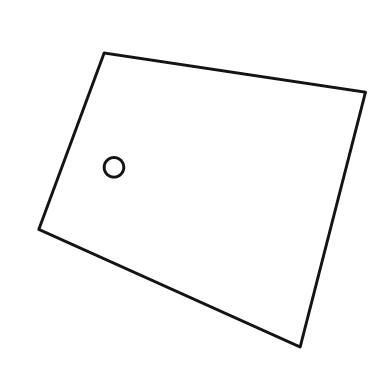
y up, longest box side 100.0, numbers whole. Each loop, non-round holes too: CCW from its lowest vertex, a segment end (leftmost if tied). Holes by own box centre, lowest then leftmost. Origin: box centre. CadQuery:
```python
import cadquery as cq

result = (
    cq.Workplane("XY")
    .moveTo(30.0, -45.0)
    .lineTo(50.0, 33.0)
    .lineTo(-30.0, 45.0)
    .lineTo(-50.0, -9.0)
    .close()
    .moveTo(-27.0, 10.0)
    .circle(3.0)
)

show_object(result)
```